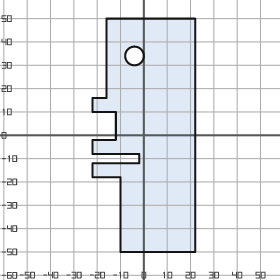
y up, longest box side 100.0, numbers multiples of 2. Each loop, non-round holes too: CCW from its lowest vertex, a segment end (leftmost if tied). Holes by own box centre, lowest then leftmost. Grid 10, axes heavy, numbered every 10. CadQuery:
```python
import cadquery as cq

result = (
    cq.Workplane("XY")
    .moveTo(-10.0, -50.0)
    .lineTo(22.0, -50.0)
    .lineTo(22.0, 50.0)
    .lineTo(-16.0, 50.0)
    .lineTo(-16.0, 16.0)
    .lineTo(-22.0, 16.0)
    .lineTo(-22.0, 10.0)
    .lineTo(-12.0, 10.0)
    .lineTo(-12.0, -2.0)
    .lineTo(-22.0, -2.0)
    .lineTo(-22.0, -8.0)
    .lineTo(-2.0, -8.0)
    .lineTo(-2.0, -12.0)
    .lineTo(-22.0, -12.0)
    .lineTo(-22.0, -18.0)
    .lineTo(-10.0, -18.0)
    .close()
    .moveTo(-4.0, 34.0)
    .circle(4.0)
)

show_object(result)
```